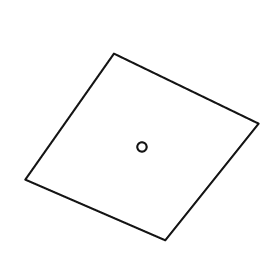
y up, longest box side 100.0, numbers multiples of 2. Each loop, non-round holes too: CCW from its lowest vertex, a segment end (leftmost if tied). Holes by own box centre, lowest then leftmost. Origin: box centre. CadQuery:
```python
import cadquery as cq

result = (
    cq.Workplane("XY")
    .moveTo(10.0, -40.0)
    .lineTo(50.0, 10.0)
    .lineTo(-12.0, 40.0)
    .lineTo(-50.0, -14.0)
    .close()
    .moveTo(0.0, 0.0)
    .circle(2.0)
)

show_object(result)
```